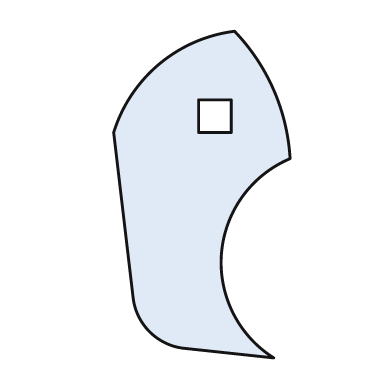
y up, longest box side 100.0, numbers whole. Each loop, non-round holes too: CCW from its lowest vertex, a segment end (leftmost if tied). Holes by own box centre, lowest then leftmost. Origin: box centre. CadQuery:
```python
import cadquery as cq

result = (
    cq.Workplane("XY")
    .moveTo(22.0, -50.0)
    .threePointArc((6.0, -18.0), (27.0, 11.0))
    .threePointArc((22.0, 32.0), (10.0, 50.0))
    .threePointArc((-13.0, 40.0), (-27.0, 19.0))
    .lineTo(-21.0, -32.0)
    .threePointArc((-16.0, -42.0), (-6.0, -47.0))
    .close()
    .moveTo(-1.0, 19.0)
    .lineTo(9.0, 19.0)
    .lineTo(9.0, 29.0)
    .lineTo(-1.0, 29.0)
    .close()
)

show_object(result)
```